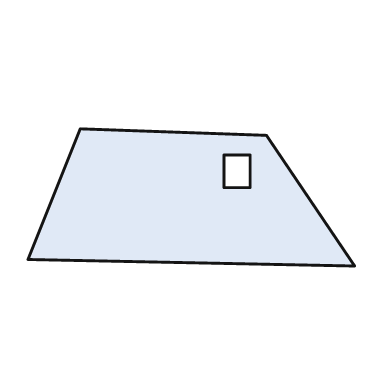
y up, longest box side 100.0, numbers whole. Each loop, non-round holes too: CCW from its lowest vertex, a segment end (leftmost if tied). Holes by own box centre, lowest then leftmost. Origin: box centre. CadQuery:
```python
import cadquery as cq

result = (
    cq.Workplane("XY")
    .moveTo(50.0, -21.0)
    .lineTo(23.0, 19.0)
    .lineTo(-34.0, 21.0)
    .lineTo(-50.0, -19.0)
    .close()
    .moveTo(10.0, 3.0)
    .lineTo(18.0, 3.0)
    .lineTo(18.0, 13.0)
    .lineTo(10.0, 13.0)
    .close()
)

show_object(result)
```